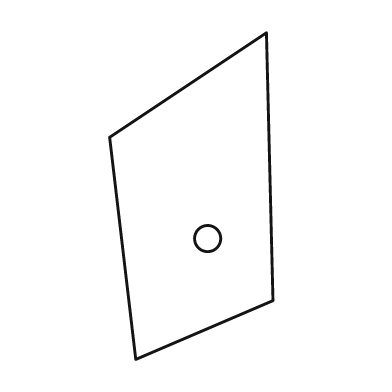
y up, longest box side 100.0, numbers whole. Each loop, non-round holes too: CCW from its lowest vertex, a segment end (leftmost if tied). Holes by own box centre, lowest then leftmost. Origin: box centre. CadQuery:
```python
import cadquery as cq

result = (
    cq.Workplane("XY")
    .moveTo(-17.0, -50.0)
    .lineTo(25.0, -32.0)
    .lineTo(23.0, 50.0)
    .lineTo(-25.0, 18.0)
    .close()
    .moveTo(5.0, -13.0)
    .circle(4.0)
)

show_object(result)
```